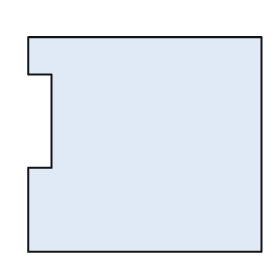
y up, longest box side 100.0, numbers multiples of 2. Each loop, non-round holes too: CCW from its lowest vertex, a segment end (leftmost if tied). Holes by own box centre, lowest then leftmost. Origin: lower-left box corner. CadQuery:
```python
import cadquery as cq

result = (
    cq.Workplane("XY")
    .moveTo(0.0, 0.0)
    .lineTo(100.0, 0.0)
    .lineTo(100.0, 92.0)
    .lineTo(0.0, 92.0)
    .lineTo(0.0, 76.0)
    .lineTo(10.0, 76.0)
    .lineTo(10.0, 36.0)
    .lineTo(0.0, 36.0)
    .close()
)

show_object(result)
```